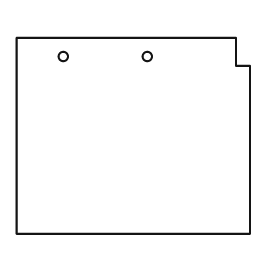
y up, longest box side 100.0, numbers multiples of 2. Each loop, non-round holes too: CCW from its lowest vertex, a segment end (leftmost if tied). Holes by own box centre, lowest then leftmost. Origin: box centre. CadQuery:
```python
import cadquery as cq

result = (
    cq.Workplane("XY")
    .moveTo(-50.0, -42.0)
    .lineTo(50.0, -42.0)
    .lineTo(50.0, 30.0)
    .lineTo(44.0, 30.0)
    .lineTo(44.0, 42.0)
    .lineTo(-50.0, 42.0)
    .close()
    .moveTo(-30.0, 34.0)
    .circle(2.0)
    .moveTo(6.0, 34.0)
    .circle(2.0)
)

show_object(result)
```